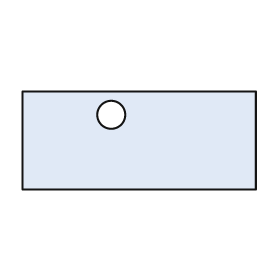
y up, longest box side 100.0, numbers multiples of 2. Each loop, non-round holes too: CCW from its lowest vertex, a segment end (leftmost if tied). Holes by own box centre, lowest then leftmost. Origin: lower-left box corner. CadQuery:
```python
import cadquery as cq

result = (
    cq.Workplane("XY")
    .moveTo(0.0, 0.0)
    .lineTo(100.0, 0.0)
    .lineTo(100.0, 42.0)
    .lineTo(0.0, 42.0)
    .close()
    .moveTo(38.0, 32.0)
    .circle(6.0)
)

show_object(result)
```